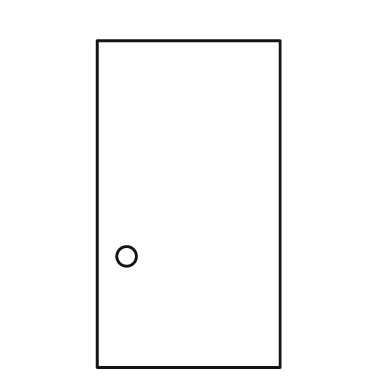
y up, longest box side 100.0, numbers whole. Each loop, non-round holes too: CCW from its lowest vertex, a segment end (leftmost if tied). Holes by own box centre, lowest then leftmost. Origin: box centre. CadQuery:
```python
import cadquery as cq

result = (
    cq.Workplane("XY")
    .moveTo(-28.0, -50.0)
    .lineTo(28.0, -50.0)
    .lineTo(28.0, 50.0)
    .lineTo(-28.0, 50.0)
    .close()
    .moveTo(-19.0, -16.0)
    .circle(3.0)
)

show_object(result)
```